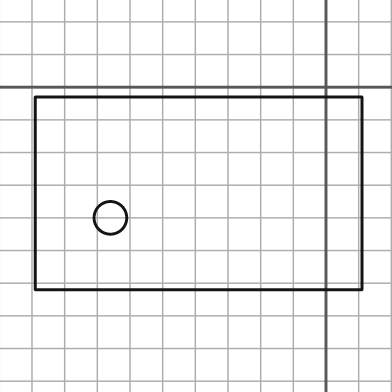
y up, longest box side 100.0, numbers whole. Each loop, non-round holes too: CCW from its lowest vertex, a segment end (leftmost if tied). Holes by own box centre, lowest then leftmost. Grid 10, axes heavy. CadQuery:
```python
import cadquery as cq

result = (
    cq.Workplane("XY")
    .moveTo(-89.0, -62.0)
    .lineTo(11.0, -62.0)
    .lineTo(11.0, -3.0)
    .lineTo(-89.0, -3.0)
    .close()
    .moveTo(-66.0, -40.0)
    .circle(5.0)
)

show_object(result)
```